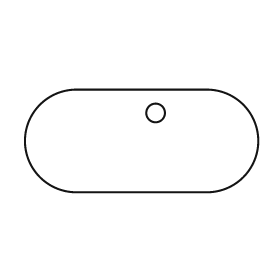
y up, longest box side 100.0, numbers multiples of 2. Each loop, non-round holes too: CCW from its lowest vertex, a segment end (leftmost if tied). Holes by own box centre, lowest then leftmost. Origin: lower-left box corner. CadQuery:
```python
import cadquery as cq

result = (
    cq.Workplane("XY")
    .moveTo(22.0, 0.0)
    .lineTo(78.0, 0.0)
    .threePointArc((100.0, 22.0), (78.0, 44.0))
    .lineTo(22.0, 44.0)
    .threePointArc((0.0, 22.0), (22.0, 0.0))
    .close()
    .moveTo(56.0, 34.0)
    .circle(4.0)
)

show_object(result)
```